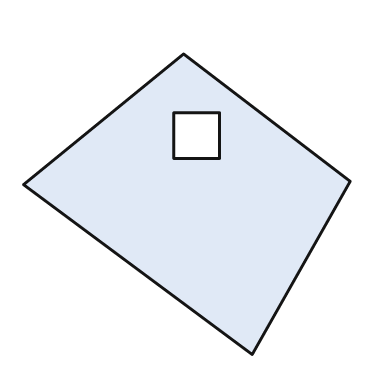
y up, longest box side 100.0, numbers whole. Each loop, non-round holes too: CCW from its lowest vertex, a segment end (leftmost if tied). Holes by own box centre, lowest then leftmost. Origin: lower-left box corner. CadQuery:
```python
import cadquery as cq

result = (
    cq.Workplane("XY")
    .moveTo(70.0, 0.0)
    .lineTo(100.0, 53.0)
    .lineTo(49.0, 92.0)
    .lineTo(0.0, 52.0)
    .close()
    .moveTo(46.0, 60.0)
    .lineTo(60.0, 60.0)
    .lineTo(60.0, 74.0)
    .lineTo(46.0, 74.0)
    .close()
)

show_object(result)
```